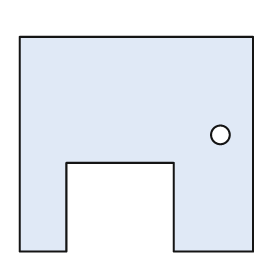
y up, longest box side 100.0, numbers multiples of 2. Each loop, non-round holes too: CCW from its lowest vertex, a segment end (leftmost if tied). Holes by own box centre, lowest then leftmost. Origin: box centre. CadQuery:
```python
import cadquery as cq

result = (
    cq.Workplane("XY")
    .moveTo(-50.0, -46.0)
    .lineTo(-30.0, -46.0)
    .lineTo(-30.0, -8.0)
    .lineTo(16.0, -8.0)
    .lineTo(16.0, -46.0)
    .lineTo(50.0, -46.0)
    .lineTo(50.0, 46.0)
    .lineTo(-50.0, 46.0)
    .close()
    .moveTo(36.0, 4.0)
    .circle(4.0)
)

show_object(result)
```